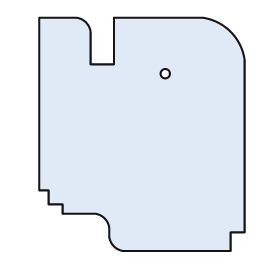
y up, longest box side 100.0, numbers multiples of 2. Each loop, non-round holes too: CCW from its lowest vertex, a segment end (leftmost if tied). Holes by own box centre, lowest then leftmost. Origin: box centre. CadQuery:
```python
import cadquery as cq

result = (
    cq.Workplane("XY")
    .moveTo(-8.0, -50.0)
    .lineTo(38.0, -50.0)
    .lineTo(38.0, -42.0)
    .lineTo(44.0, -42.0)
    .lineTo(44.0, 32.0)
    .threePointArc((38.0, 44.0), (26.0, 50.0))
    .lineTo(-12.0, 50.0)
    .lineTo(-12.0, 30.0)
    .lineTo(-22.0, 30.0)
    .lineTo(-22.0, 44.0)
    .threePointArc((-24.0, 48.0), (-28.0, 50.0))
    .lineTo(-44.0, 50.0)
    .lineTo(-44.0, -24.0)
    .lineTo(-40.0, -24.0)
    .lineTo(-40.0, -30.0)
    .lineTo(-34.0, -30.0)
    .lineTo(-34.0, -34.0)
    .lineTo(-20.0, -34.0)
    .threePointArc((-16.0, -36.0), (-14.0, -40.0))
    .lineTo(-14.0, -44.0)
    .threePointArc((-12.0, -48.0), (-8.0, -50.0))
    .close()
    .moveTo(10.0, 26.0)
    .circle(2.0)
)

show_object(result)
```